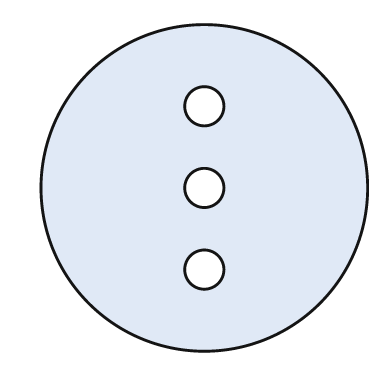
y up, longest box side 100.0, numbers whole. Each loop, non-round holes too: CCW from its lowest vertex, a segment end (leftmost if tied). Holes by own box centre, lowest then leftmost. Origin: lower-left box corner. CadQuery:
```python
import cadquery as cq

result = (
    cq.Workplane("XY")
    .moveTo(50.0, 50.0)
    .circle(50.0)
    .moveTo(50.0, 25.0)
    .circle(6.0)
    .moveTo(50.0, 50.0)
    .circle(6.0)
    .moveTo(50.0, 75.0)
    .circle(6.0)
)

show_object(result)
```